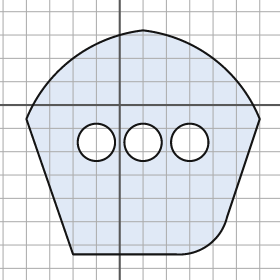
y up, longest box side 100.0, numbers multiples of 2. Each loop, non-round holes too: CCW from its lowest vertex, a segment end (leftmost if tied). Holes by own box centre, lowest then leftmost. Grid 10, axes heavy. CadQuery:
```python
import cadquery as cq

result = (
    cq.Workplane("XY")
    .moveTo(-20.0, -64.0)
    .lineTo(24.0, -64.0)
    .threePointArc((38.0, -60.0), (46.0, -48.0))
    .lineTo(60.0, -6.0)
    .threePointArc((40.0, 20.0), (10.0, 32.0))
    .threePointArc((-20.0, 20.0), (-40.0, -6.0))
    .close()
    .moveTo(-10.0, -16.0)
    .circle(8.0)
    .moveTo(10.0, -16.0)
    .circle(8.0)
    .moveTo(30.0, -16.0)
    .circle(8.0)
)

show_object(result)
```